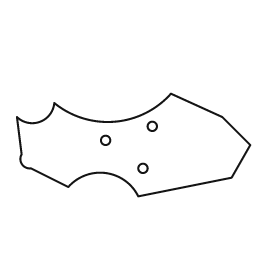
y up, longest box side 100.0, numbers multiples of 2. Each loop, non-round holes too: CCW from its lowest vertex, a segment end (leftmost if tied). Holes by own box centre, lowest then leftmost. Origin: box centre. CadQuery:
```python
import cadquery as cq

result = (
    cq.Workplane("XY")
    .moveTo(2.0, -22.0)
    .lineTo(42.0, -14.0)
    .lineTo(50.0, 0.0)
    .lineTo(38.0, 12.0)
    .lineTo(16.0, 22.0)
    .threePointArc((-8.0, 10.0), (-34.0, 18.0))
    .threePointArc((-40.0, 10.0), (-50.0, 12.0))
    .lineTo(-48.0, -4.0)
    .threePointArc((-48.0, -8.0), (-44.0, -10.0))
    .lineTo(-28.0, -18.0)
    .threePointArc((-12.0, -12.0), (2.0, -22.0))
    .close()
    .moveTo(4.0, -10.0)
    .circle(2.0)
    .moveTo(-12.0, 2.0)
    .circle(2.0)
    .moveTo(8.0, 8.0)
    .circle(2.0)
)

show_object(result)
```